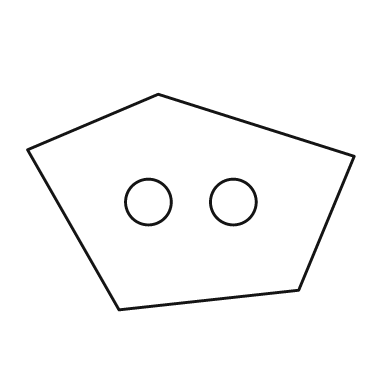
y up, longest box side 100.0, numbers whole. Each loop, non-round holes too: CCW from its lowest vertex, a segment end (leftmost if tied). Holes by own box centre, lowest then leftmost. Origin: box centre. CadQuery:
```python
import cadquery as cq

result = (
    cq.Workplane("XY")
    .moveTo(-22.0, -33.0)
    .lineTo(33.0, -27.0)
    .lineTo(50.0, 14.0)
    .lineTo(-10.0, 33.0)
    .lineTo(-50.0, 16.0)
    .close()
    .moveTo(-13.0, 0.0)
    .circle(7.0)
    .moveTo(13.0, 0.0)
    .circle(7.0)
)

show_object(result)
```